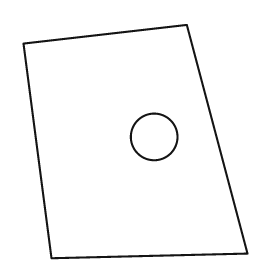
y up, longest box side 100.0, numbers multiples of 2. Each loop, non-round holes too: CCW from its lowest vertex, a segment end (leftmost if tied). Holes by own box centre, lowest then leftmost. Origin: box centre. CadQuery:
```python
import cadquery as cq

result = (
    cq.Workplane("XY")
    .moveTo(-36.0, -50.0)
    .lineTo(48.0, -48.0)
    .lineTo(22.0, 50.0)
    .lineTo(-48.0, 42.0)
    .close()
    .moveTo(8.0, 2.0)
    .circle(10.0)
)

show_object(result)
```